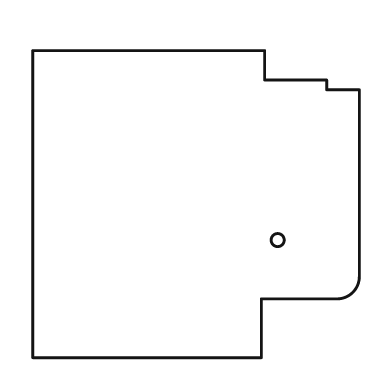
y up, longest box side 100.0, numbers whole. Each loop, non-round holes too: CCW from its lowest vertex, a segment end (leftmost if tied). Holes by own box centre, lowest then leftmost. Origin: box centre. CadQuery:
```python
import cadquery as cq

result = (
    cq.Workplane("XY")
    .moveTo(-50.0, -47.0)
    .lineTo(20.0, -47.0)
    .lineTo(20.0, -29.0)
    .lineTo(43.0, -29.0)
    .threePointArc((48.0, -27.0), (50.0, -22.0))
    .lineTo(50.0, 35.0)
    .lineTo(40.0, 35.0)
    .lineTo(40.0, 38.0)
    .lineTo(21.0, 38.0)
    .lineTo(21.0, 47.0)
    .lineTo(-50.0, 47.0)
    .close()
    .moveTo(25.0, -11.0)
    .circle(2.0)
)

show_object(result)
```